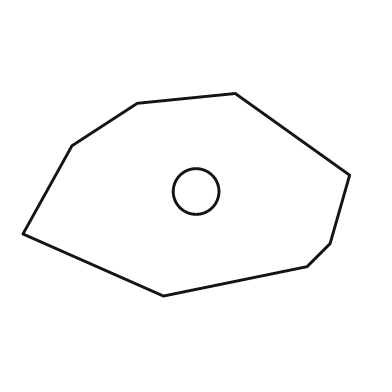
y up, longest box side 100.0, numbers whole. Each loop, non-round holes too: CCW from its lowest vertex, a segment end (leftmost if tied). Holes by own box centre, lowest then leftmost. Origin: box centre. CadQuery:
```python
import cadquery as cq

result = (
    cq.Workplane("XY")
    .moveTo(-7.0, -31.0)
    .lineTo(37.0, -22.0)
    .lineTo(44.0, -15.0)
    .lineTo(50.0, 6.0)
    .lineTo(15.0, 31.0)
    .lineTo(-15.0, 28.0)
    .lineTo(-35.0, 15.0)
    .lineTo(-50.0, -12.0)
    .close()
    .moveTo(3.0, 1.0)
    .circle(7.0)
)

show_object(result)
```